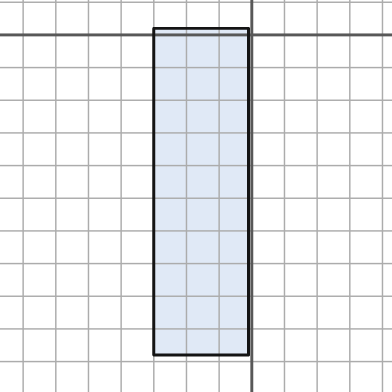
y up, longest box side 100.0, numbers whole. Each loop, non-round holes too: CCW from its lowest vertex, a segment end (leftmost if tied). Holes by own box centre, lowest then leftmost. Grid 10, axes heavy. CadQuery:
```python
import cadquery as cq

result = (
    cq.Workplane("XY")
    .moveTo(-30.0, -98.0)
    .lineTo(-1.0, -98.0)
    .lineTo(-1.0, 2.0)
    .lineTo(-30.0, 2.0)
    .close()
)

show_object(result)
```